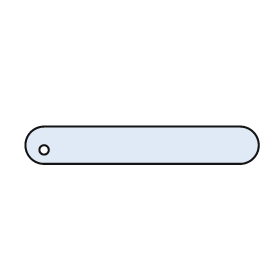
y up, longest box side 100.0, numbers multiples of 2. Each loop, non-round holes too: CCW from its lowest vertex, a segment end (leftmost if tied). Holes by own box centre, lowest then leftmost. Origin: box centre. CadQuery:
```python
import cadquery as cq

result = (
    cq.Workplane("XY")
    .moveTo(-42.0, -8.0)
    .lineTo(42.0, -8.0)
    .threePointArc((50.0, 0.0), (42.0, 8.0))
    .lineTo(-42.0, 8.0)
    .threePointArc((-50.0, 0.0), (-42.0, -8.0))
    .close()
    .moveTo(-42.0, -2.0)
    .circle(2.0)
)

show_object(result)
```